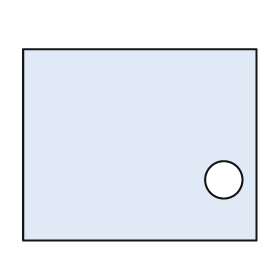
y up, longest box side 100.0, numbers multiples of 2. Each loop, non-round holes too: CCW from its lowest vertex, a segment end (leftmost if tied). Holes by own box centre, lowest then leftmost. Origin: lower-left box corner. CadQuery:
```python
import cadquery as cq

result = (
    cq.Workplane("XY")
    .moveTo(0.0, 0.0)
    .lineTo(100.0, 0.0)
    .lineTo(100.0, 82.0)
    .lineTo(0.0, 82.0)
    .close()
    .moveTo(86.0, 26.0)
    .circle(8.0)
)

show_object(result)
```